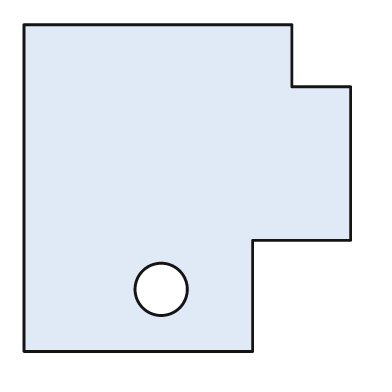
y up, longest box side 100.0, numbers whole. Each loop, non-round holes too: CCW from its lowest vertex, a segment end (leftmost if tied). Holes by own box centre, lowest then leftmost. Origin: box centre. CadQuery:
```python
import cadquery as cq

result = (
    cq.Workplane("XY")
    .moveTo(-50.0, -50.0)
    .lineTo(20.0, -50.0)
    .lineTo(20.0, -16.0)
    .lineTo(50.0, -16.0)
    .lineTo(50.0, 31.0)
    .lineTo(32.0, 31.0)
    .lineTo(32.0, 50.0)
    .lineTo(-50.0, 50.0)
    .close()
    .moveTo(-8.0, -31.0)
    .circle(8.0)
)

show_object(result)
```